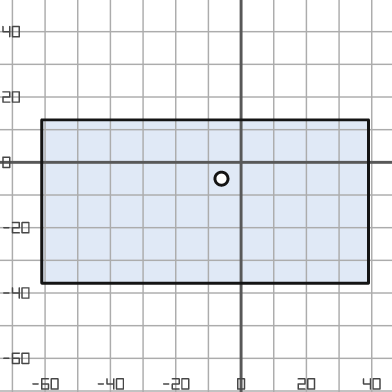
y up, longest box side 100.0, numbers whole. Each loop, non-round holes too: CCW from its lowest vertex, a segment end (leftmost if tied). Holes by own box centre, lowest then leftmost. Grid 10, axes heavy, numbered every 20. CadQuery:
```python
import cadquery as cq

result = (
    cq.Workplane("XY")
    .moveTo(-61.0, -37.0)
    .lineTo(39.0, -37.0)
    .lineTo(39.0, 13.0)
    .lineTo(-61.0, 13.0)
    .close()
    .moveTo(-6.0, -5.0)
    .circle(2.0)
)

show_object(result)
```